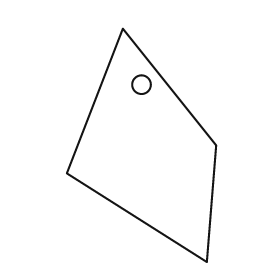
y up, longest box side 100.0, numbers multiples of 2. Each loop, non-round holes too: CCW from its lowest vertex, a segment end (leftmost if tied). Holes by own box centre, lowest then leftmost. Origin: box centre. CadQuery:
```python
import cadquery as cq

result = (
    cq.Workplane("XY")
    .moveTo(28.0, -50.0)
    .lineTo(32.0, 0.0)
    .lineTo(-8.0, 50.0)
    .lineTo(-32.0, -12.0)
    .close()
    .moveTo(0.0, 26.0)
    .circle(4.0)
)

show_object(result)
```